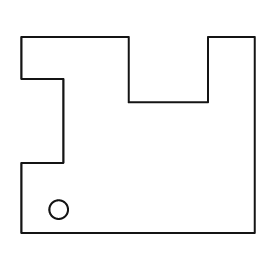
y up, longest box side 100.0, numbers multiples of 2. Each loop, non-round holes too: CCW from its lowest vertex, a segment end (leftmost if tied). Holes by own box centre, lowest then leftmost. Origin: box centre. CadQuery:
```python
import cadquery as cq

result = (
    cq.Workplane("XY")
    .moveTo(-50.0, -42.0)
    .lineTo(50.0, -42.0)
    .lineTo(50.0, 42.0)
    .lineTo(30.0, 42.0)
    .lineTo(30.0, 14.0)
    .lineTo(-4.0, 14.0)
    .lineTo(-4.0, 42.0)
    .lineTo(-50.0, 42.0)
    .lineTo(-50.0, 24.0)
    .lineTo(-32.0, 24.0)
    .lineTo(-32.0, -12.0)
    .lineTo(-50.0, -12.0)
    .close()
    .moveTo(-34.0, -32.0)
    .circle(4.0)
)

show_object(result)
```